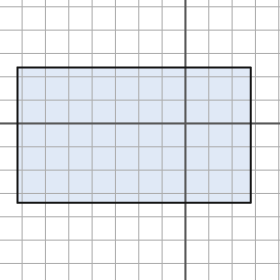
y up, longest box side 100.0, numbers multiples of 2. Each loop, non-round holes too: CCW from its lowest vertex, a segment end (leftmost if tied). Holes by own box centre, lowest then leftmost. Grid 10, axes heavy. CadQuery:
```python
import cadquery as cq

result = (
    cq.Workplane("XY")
    .moveTo(-72.0, -34.0)
    .lineTo(28.0, -34.0)
    .lineTo(28.0, 24.0)
    .lineTo(-72.0, 24.0)
    .close()
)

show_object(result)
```